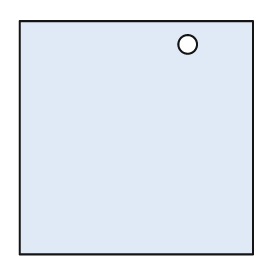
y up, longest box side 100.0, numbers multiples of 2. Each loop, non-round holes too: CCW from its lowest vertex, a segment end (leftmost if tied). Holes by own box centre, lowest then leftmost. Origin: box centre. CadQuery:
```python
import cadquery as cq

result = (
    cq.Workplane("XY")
    .moveTo(-50.0, -50.0)
    .lineTo(50.0, -50.0)
    .lineTo(50.0, 50.0)
    .lineTo(-50.0, 50.0)
    .close()
    .moveTo(22.0, 40.0)
    .circle(4.0)
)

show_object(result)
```